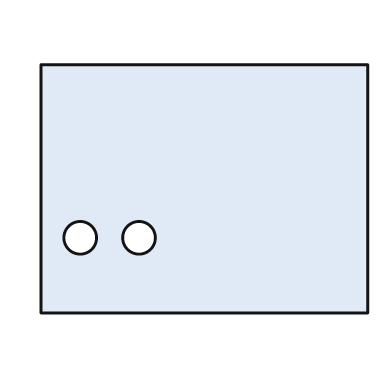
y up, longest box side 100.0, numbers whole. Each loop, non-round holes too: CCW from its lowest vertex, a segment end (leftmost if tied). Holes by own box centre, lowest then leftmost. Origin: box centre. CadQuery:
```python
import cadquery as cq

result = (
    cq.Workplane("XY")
    .moveTo(-50.0, -38.0)
    .lineTo(50.0, -38.0)
    .lineTo(50.0, 38.0)
    .lineTo(-50.0, 38.0)
    .close()
    .moveTo(-38.0, -15.0)
    .circle(5.0)
    .moveTo(-20.0, -15.0)
    .circle(5.0)
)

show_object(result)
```